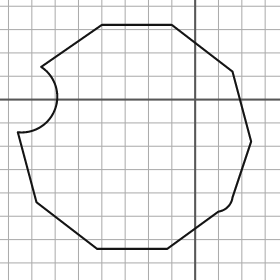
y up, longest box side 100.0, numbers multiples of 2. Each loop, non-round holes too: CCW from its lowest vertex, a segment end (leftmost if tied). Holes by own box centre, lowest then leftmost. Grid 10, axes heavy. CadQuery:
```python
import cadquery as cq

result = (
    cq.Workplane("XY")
    .moveTo(-42.0, -64.0)
    .lineTo(-12.0, -64.0)
    .lineTo(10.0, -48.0)
    .threePointArc((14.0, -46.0), (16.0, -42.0))
    .lineTo(24.0, -18.0)
    .lineTo(16.0, 12.0)
    .lineTo(-10.0, 32.0)
    .lineTo(-40.0, 32.0)
    .lineTo(-66.0, 14.0)
    .threePointArc((-60.0, -4.0), (-76.0, -14.0))
    .lineTo(-68.0, -44.0)
    .close()
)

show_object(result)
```